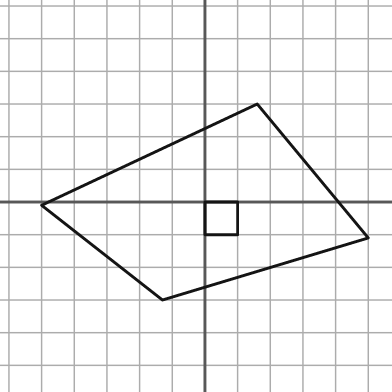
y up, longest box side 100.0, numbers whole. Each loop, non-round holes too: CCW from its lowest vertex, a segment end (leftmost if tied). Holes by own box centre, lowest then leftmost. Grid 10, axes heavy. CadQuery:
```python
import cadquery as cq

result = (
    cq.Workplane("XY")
    .moveTo(-13.0, -30.0)
    .lineTo(50.0, -11.0)
    .lineTo(16.0, 30.0)
    .lineTo(-50.0, -1.0)
    .close()
    .moveTo(0.0, -10.0)
    .lineTo(10.0, -10.0)
    .lineTo(10.0, 0.0)
    .lineTo(0.0, 0.0)
    .close()
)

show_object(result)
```